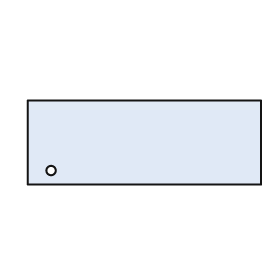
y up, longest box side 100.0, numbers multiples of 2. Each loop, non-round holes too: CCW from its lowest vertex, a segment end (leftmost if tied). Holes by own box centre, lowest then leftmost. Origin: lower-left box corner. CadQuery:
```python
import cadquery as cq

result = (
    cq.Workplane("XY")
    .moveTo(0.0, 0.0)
    .lineTo(100.0, 0.0)
    .lineTo(100.0, 36.0)
    .lineTo(0.0, 36.0)
    .close()
    .moveTo(10.0, 6.0)
    .circle(2.0)
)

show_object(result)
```